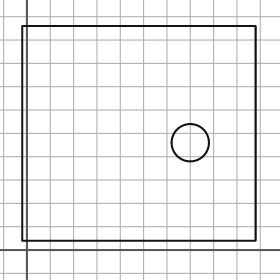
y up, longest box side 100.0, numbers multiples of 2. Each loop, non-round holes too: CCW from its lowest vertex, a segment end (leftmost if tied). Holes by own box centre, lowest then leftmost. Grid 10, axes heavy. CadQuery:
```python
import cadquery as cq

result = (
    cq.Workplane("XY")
    .moveTo(-2.0, 4.0)
    .lineTo(98.0, 4.0)
    .lineTo(98.0, 96.0)
    .lineTo(-2.0, 96.0)
    .close()
    .moveTo(70.0, 46.0)
    .circle(8.0)
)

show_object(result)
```